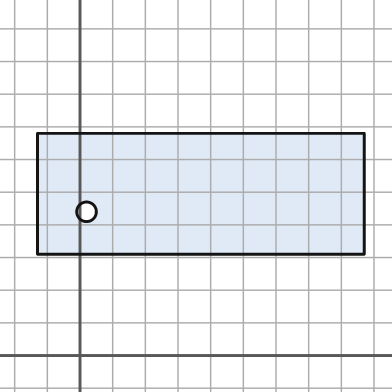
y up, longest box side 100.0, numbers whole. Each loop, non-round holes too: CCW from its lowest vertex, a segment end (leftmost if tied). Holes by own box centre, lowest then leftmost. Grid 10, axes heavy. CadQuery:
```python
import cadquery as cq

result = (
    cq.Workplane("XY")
    .moveTo(-13.0, 31.0)
    .lineTo(87.0, 31.0)
    .lineTo(87.0, 68.0)
    .lineTo(-13.0, 68.0)
    .close()
    .moveTo(2.0, 44.0)
    .circle(3.0)
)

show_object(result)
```